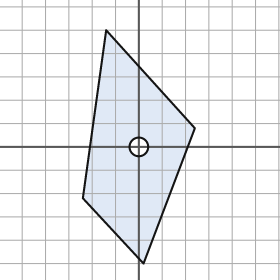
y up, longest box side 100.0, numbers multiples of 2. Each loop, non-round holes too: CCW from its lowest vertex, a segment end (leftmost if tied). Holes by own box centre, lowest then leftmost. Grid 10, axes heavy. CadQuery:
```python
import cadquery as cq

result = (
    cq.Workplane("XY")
    .moveTo(2.0, -50.0)
    .lineTo(24.0, 8.0)
    .lineTo(-14.0, 50.0)
    .lineTo(-24.0, -22.0)
    .close()
    .moveTo(0.0, 0.0)
    .circle(4.0)
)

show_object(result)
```